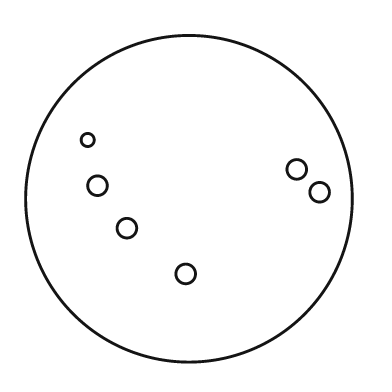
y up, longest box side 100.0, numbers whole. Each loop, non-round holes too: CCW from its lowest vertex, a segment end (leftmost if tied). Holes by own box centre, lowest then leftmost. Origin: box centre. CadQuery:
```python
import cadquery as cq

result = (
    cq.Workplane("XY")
    .moveTo(0.0, 0.0)
    .circle(50.0)
    .moveTo(-1.0, -23.0)
    .circle(3.0)
    .moveTo(-19.0, -9.0)
    .circle(3.0)
    .moveTo(40.0, 2.0)
    .circle(3.0)
    .moveTo(-28.0, 4.0)
    .circle(3.0)
    .moveTo(33.0, 9.0)
    .circle(3.0)
    .moveTo(-31.0, 18.0)
    .circle(2.0)
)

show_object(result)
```